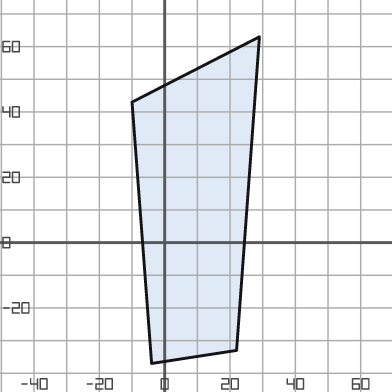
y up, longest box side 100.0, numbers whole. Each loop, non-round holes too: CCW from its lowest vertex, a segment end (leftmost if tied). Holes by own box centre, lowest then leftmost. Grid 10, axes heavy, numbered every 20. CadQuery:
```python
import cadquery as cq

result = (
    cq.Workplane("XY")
    .moveTo(-4.0, -37.0)
    .lineTo(22.0, -33.0)
    .lineTo(29.0, 63.0)
    .lineTo(-10.0, 43.0)
    .close()
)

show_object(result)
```